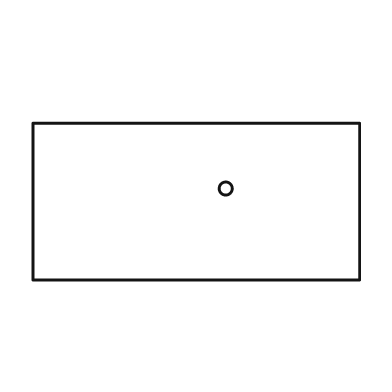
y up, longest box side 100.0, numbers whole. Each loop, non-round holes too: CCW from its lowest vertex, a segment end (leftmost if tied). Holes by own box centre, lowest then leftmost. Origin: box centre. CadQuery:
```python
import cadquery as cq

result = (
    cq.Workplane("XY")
    .moveTo(-50.0, -24.0)
    .lineTo(50.0, -24.0)
    .lineTo(50.0, 24.0)
    .lineTo(-50.0, 24.0)
    .close()
    .moveTo(9.0, 4.0)
    .circle(2.0)
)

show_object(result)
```